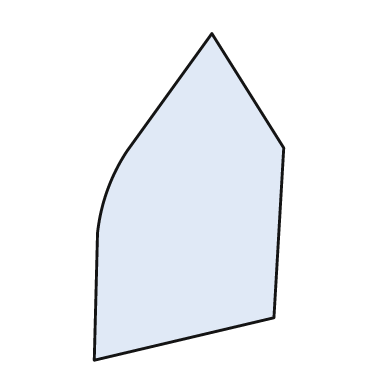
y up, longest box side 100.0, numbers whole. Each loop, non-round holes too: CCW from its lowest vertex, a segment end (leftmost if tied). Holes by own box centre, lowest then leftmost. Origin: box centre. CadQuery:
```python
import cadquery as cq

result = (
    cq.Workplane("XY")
    .moveTo(-29.0, -50.0)
    .lineTo(26.0, -37.0)
    .lineTo(29.0, 15.0)
    .lineTo(7.0, 50.0)
    .lineTo(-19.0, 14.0)
    .threePointArc((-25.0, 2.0), (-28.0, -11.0))
    .close()
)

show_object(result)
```